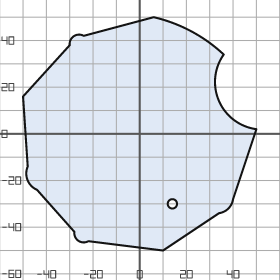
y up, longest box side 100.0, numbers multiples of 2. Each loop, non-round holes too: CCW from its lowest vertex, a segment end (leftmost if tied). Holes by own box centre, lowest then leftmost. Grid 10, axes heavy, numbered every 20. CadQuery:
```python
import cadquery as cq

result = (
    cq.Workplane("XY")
    .moveTo(10.0, -50.0)
    .lineTo(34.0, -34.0)
    .threePointArc((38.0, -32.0), (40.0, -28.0))
    .lineTo(50.0, 2.0)
    .threePointArc((34.0, 14.0), (36.0, 34.0))
    .threePointArc((22.0, 44.0), (6.0, 50.0))
    .lineTo(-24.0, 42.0)
    .threePointArc((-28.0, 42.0), (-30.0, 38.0))
    .lineTo(-50.0, 16.0)
    .lineTo(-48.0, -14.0)
    .threePointArc((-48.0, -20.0), (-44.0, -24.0))
    .lineTo(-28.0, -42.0)
    .threePointArc((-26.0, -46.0), (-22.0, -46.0))
    .close()
    .moveTo(14.0, -30.0)
    .circle(2.0)
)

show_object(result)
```